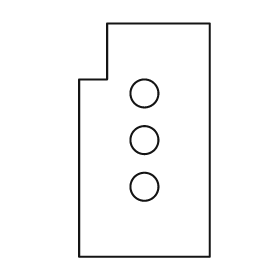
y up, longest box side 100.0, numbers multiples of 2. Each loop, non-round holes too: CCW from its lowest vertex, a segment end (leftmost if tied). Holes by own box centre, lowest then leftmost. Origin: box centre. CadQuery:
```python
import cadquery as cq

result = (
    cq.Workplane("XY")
    .moveTo(-28.0, -50.0)
    .lineTo(28.0, -50.0)
    .lineTo(28.0, 50.0)
    .lineTo(-16.0, 50.0)
    .lineTo(-16.0, 26.0)
    .lineTo(-28.0, 26.0)
    .close()
    .moveTo(0.0, -20.0)
    .circle(6.0)
    .moveTo(0.0, 0.0)
    .circle(6.0)
    .moveTo(0.0, 20.0)
    .circle(6.0)
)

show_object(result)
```